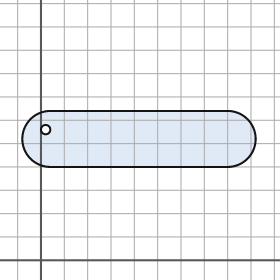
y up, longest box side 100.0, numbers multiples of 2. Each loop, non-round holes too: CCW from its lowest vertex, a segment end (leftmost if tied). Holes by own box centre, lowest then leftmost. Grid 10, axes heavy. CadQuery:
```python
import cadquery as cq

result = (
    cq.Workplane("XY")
    .moveTo(4.0, 40.0)
    .lineTo(80.0, 40.0)
    .threePointArc((92.0, 52.0), (80.0, 64.0))
    .lineTo(4.0, 64.0)
    .threePointArc((-8.0, 52.0), (4.0, 40.0))
    .close()
    .moveTo(2.0, 56.0)
    .circle(2.0)
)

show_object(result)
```